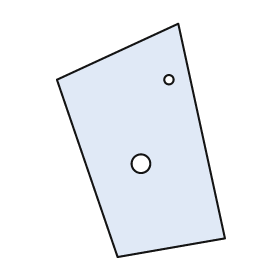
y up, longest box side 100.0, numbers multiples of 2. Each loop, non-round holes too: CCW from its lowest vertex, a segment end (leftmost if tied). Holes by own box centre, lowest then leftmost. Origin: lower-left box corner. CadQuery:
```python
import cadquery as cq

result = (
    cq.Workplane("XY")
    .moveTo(26.0, 0.0)
    .lineTo(72.0, 8.0)
    .lineTo(52.0, 100.0)
    .lineTo(0.0, 76.0)
    .close()
    .moveTo(36.0, 40.0)
    .circle(4.0)
    .moveTo(48.0, 76.0)
    .circle(2.0)
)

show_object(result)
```